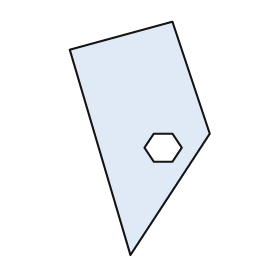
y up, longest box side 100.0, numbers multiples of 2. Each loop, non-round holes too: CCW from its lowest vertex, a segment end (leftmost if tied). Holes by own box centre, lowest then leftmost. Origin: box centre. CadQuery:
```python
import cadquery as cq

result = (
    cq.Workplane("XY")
    .moveTo(-4.0, -50.0)
    .lineTo(30.0, 2.0)
    .lineTo(14.0, 50.0)
    .lineTo(-30.0, 38.0)
    .close()
    .moveTo(6.0, -10.0)
    .lineTo(14.0, -10.0)
    .lineTo(18.0, -4.0)
    .lineTo(14.0, 2.0)
    .lineTo(6.0, 2.0)
    .lineTo(2.0, -4.0)
    .close()
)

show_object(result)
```